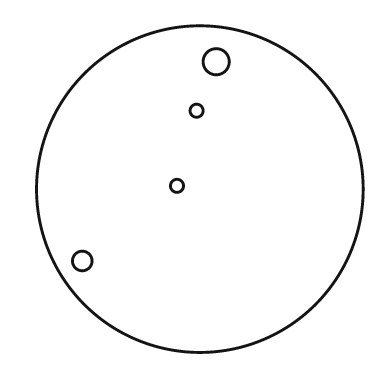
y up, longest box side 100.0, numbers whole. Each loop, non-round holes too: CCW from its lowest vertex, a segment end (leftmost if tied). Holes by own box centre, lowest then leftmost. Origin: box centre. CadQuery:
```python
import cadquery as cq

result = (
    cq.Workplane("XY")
    .moveTo(0.0, 0.0)
    .circle(50.0)
    .moveTo(-36.0, -22.0)
    .circle(3.0)
    .moveTo(-7.0, 1.0)
    .circle(2.0)
    .moveTo(-1.0, 24.0)
    .circle(2.0)
    .moveTo(5.0, 39.0)
    .circle(4.0)
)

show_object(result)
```